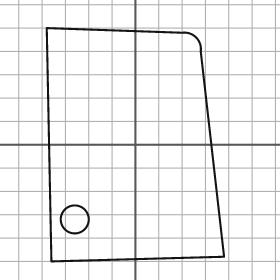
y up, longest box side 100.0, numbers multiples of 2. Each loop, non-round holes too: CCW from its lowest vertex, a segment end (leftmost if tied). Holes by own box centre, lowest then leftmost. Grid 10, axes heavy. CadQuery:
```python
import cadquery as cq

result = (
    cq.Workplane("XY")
    .moveTo(-36.0, -50.0)
    .lineTo(38.0, -48.0)
    .lineTo(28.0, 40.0)
    .threePointArc((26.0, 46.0), (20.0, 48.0))
    .lineTo(-38.0, 50.0)
    .close()
    .moveTo(-26.0, -32.0)
    .circle(6.0)
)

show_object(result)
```